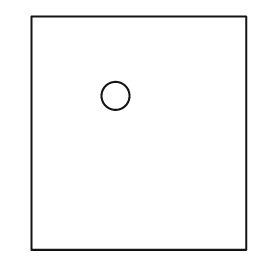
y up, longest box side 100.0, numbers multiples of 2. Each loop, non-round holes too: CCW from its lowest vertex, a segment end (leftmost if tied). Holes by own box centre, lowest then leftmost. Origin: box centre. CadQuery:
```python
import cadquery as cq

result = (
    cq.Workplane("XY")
    .moveTo(-46.0, -50.0)
    .lineTo(46.0, -50.0)
    .lineTo(46.0, 50.0)
    .lineTo(-46.0, 50.0)
    .close()
    .moveTo(-10.0, 16.0)
    .circle(6.0)
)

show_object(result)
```